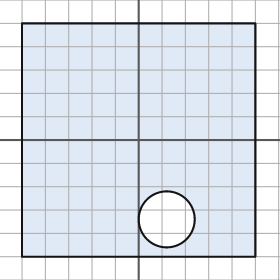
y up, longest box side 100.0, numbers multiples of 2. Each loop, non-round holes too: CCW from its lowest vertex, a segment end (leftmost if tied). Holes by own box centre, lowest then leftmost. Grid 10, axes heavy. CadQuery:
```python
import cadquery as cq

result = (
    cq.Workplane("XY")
    .moveTo(-50.0, -50.0)
    .lineTo(50.0, -50.0)
    .lineTo(50.0, 50.0)
    .lineTo(-50.0, 50.0)
    .close()
    .moveTo(12.0, -34.0)
    .circle(12.0)
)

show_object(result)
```